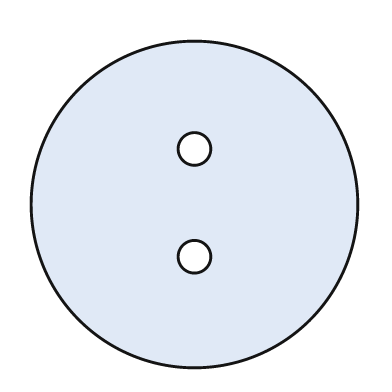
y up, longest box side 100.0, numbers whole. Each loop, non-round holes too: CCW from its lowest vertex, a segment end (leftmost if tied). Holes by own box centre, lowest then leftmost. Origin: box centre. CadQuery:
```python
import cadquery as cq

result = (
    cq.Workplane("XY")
    .moveTo(0.0, 0.0)
    .circle(50.0)
    .moveTo(0.0, -16.0)
    .circle(5.0)
    .moveTo(0.0, 17.0)
    .circle(5.0)
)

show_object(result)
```